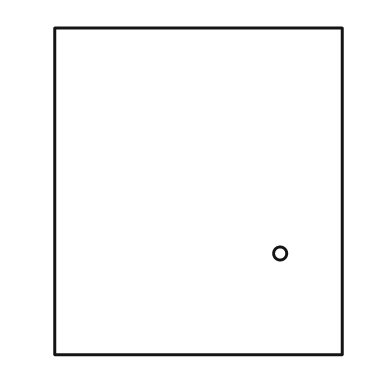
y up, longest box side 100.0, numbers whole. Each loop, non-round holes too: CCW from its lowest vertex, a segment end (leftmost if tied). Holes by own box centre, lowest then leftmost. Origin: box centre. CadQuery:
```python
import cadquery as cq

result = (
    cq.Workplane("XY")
    .moveTo(-44.0, -50.0)
    .lineTo(44.0, -50.0)
    .lineTo(44.0, 50.0)
    .lineTo(-44.0, 50.0)
    .close()
    .moveTo(25.0, -19.0)
    .circle(2.0)
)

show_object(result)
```